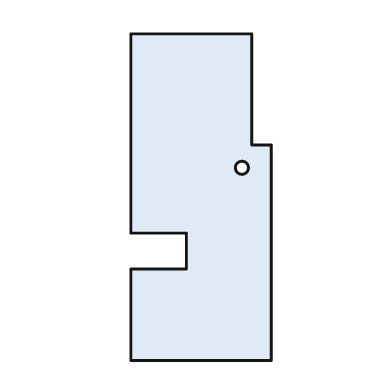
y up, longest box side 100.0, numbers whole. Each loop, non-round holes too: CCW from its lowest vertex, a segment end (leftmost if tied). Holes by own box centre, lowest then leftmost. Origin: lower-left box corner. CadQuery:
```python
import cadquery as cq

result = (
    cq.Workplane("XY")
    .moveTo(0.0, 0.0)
    .lineTo(43.0, 0.0)
    .lineTo(43.0, 66.0)
    .lineTo(37.0, 66.0)
    .lineTo(37.0, 100.0)
    .lineTo(0.0, 100.0)
    .lineTo(0.0, 39.0)
    .lineTo(17.0, 39.0)
    .lineTo(17.0, 28.0)
    .lineTo(0.0, 28.0)
    .close()
    .moveTo(34.0, 59.0)
    .circle(2.0)
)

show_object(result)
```